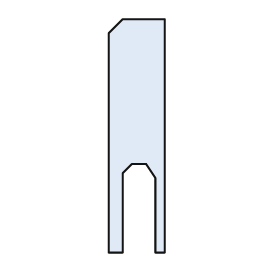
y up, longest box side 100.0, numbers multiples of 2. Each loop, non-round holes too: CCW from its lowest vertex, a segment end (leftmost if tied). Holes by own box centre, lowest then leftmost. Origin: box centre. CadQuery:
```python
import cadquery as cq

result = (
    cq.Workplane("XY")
    .moveTo(-12.0, -50.0)
    .lineTo(-6.0, -50.0)
    .lineTo(-6.0, -16.0)
    .lineTo(-2.0, -12.0)
    .lineTo(4.0, -12.0)
    .lineTo(8.0, -18.0)
    .lineTo(8.0, -50.0)
    .lineTo(12.0, -50.0)
    .lineTo(12.0, 50.0)
    .lineTo(-6.0, 50.0)
    .lineTo(-12.0, 44.0)
    .close()
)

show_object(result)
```